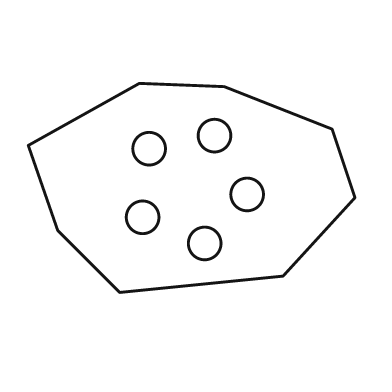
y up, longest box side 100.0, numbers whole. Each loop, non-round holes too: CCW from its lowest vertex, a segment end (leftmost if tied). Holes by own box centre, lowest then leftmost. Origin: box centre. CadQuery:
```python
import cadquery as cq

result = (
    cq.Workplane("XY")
    .moveTo(-22.0, -32.0)
    .lineTo(28.0, -27.0)
    .lineTo(50.0, -3.0)
    .lineTo(43.0, 18.0)
    .lineTo(10.0, 31.0)
    .lineTo(-16.0, 32.0)
    .lineTo(-50.0, 13.0)
    .lineTo(-41.0, -13.0)
    .close()
    .moveTo(4.0, -17.0)
    .circle(5.0)
    .moveTo(-15.0, -9.0)
    .circle(5.0)
    .moveTo(17.0, -2.0)
    .circle(5.0)
    .moveTo(-13.0, 12.0)
    .circle(5.0)
    .moveTo(7.0, 16.0)
    .circle(5.0)
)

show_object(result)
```